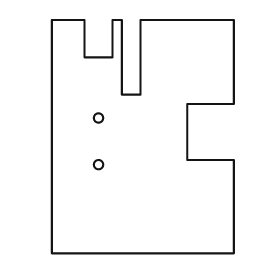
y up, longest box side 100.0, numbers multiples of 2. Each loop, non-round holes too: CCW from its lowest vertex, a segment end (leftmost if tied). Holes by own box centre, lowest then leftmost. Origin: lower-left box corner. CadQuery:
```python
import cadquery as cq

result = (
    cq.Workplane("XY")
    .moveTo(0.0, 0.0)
    .lineTo(78.0, 0.0)
    .lineTo(78.0, 40.0)
    .lineTo(58.0, 40.0)
    .lineTo(58.0, 64.0)
    .lineTo(78.0, 64.0)
    .lineTo(78.0, 100.0)
    .lineTo(38.0, 100.0)
    .lineTo(38.0, 68.0)
    .lineTo(30.0, 68.0)
    .lineTo(30.0, 100.0)
    .lineTo(26.0, 100.0)
    .lineTo(26.0, 84.0)
    .lineTo(14.0, 84.0)
    .lineTo(14.0, 100.0)
    .lineTo(0.0, 100.0)
    .close()
    .moveTo(20.0, 38.0)
    .circle(2.0)
    .moveTo(20.0, 58.0)
    .circle(2.0)
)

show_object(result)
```